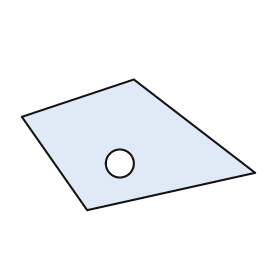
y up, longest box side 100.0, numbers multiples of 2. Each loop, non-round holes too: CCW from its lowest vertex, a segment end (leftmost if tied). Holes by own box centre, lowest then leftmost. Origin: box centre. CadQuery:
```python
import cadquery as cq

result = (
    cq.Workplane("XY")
    .moveTo(-22.0, -28.0)
    .lineTo(50.0, -12.0)
    .lineTo(-2.0, 28.0)
    .lineTo(-50.0, 12.0)
    .close()
    .moveTo(-8.0, -8.0)
    .circle(6.0)
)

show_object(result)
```